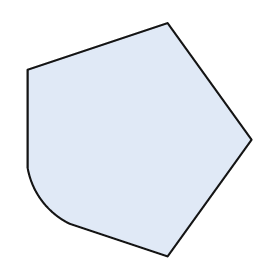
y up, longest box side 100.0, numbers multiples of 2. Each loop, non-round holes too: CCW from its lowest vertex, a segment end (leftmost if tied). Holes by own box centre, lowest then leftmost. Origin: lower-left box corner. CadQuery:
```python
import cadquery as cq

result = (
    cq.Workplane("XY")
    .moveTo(60.0, 0.0)
    .lineTo(96.0, 50.0)
    .lineTo(60.0, 100.0)
    .lineTo(0.0, 80.0)
    .lineTo(0.0, 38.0)
    .threePointArc((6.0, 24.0), (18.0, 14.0))
    .close()
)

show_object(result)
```